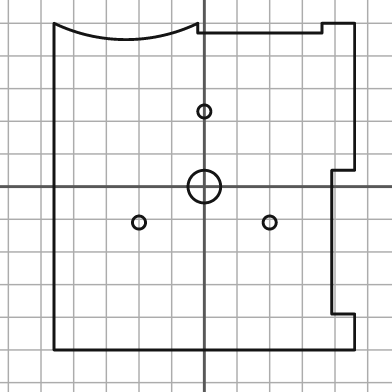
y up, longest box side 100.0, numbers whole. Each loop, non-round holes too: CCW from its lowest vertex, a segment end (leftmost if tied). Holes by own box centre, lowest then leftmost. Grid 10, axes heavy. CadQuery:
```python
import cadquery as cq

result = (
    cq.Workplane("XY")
    .moveTo(-46.0, -50.0)
    .lineTo(46.0, -50.0)
    .lineTo(46.0, -39.0)
    .lineTo(39.0, -39.0)
    .lineTo(39.0, 5.0)
    .lineTo(46.0, 5.0)
    .lineTo(46.0, 50.0)
    .lineTo(36.0, 50.0)
    .lineTo(36.0, 47.0)
    .lineTo(-2.0, 47.0)
    .lineTo(-2.0, 50.0)
    .threePointArc((-24.0, 45.0), (-46.0, 50.0))
    .close()
    .moveTo(-20.0, -11.0)
    .circle(2.0)
    .moveTo(20.0, -11.0)
    .circle(2.0)
    .moveTo(0.0, 0.0)
    .circle(5.0)
    .moveTo(0.0, 23.0)
    .circle(2.0)
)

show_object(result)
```